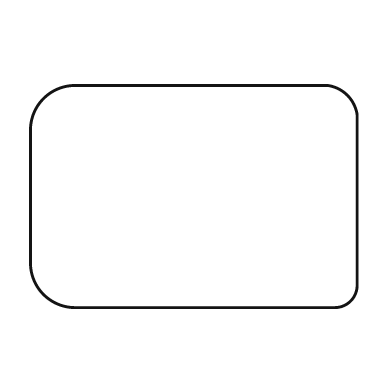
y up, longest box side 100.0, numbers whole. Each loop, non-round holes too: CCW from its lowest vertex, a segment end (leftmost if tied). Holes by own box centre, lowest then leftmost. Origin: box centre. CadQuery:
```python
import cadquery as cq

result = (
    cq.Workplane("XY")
    .moveTo(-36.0, -34.0)
    .lineTo(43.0, -34.0)
    .threePointArc((48.0, -32.0), (50.0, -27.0))
    .lineTo(50.0, 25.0)
    .threePointArc((47.0, 31.0), (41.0, 34.0))
    .lineTo(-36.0, 34.0)
    .threePointArc((-46.0, 30.0), (-50.0, 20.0))
    .lineTo(-50.0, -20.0)
    .threePointArc((-46.0, -30.0), (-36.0, -34.0))
    .close()
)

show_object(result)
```